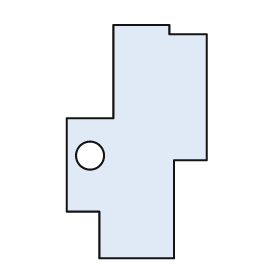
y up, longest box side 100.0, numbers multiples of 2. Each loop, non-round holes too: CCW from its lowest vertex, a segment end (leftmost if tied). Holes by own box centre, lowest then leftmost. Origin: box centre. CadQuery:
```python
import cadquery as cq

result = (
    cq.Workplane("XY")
    .moveTo(-16.0, -50.0)
    .lineTo(16.0, -50.0)
    .lineTo(16.0, -8.0)
    .lineTo(30.0, -8.0)
    .lineTo(30.0, 46.0)
    .lineTo(14.0, 46.0)
    .lineTo(14.0, 50.0)
    .lineTo(-10.0, 50.0)
    .lineTo(-10.0, 10.0)
    .lineTo(-30.0, 10.0)
    .lineTo(-30.0, -30.0)
    .lineTo(-16.0, -30.0)
    .close()
    .moveTo(-20.0, -6.0)
    .circle(6.0)
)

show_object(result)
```